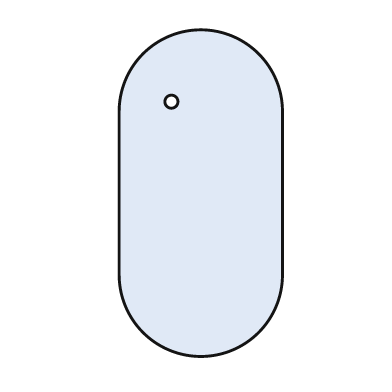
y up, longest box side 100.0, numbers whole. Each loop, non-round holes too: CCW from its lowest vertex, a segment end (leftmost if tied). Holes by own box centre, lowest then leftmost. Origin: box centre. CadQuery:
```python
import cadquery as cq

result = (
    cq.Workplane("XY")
    .moveTo(-25.0, -25.0)
    .threePointArc((0.0, -50.0), (25.0, -25.0))
    .lineTo(25.0, 25.0)
    .threePointArc((0.0, 50.0), (-25.0, 25.0))
    .close()
    .moveTo(-9.0, 28.0)
    .circle(2.0)
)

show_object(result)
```